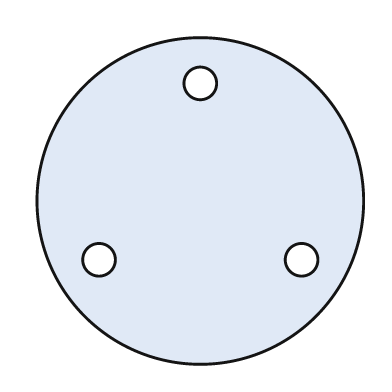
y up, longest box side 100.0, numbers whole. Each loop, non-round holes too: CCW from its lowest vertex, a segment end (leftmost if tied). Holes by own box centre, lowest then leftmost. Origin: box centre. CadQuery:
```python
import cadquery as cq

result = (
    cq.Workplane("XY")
    .moveTo(0.0, 0.0)
    .circle(50.0)
    .moveTo(-31.0, -18.0)
    .circle(5.0)
    .moveTo(31.0, -18.0)
    .circle(5.0)
    .moveTo(0.0, 36.0)
    .circle(5.0)
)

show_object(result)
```